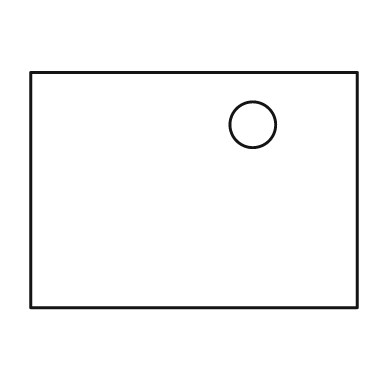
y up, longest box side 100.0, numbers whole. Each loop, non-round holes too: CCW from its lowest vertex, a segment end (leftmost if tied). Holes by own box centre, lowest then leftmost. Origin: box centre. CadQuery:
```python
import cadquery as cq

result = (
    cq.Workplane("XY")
    .moveTo(-50.0, -36.0)
    .lineTo(50.0, -36.0)
    .lineTo(50.0, 36.0)
    .lineTo(-50.0, 36.0)
    .close()
    .moveTo(18.0, 20.0)
    .circle(7.0)
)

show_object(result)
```